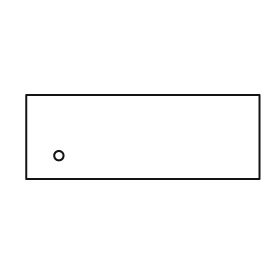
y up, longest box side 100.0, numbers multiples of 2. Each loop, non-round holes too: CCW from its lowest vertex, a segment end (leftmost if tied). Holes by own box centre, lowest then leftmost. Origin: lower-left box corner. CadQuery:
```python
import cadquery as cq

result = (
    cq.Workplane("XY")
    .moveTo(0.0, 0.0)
    .lineTo(100.0, 0.0)
    .lineTo(100.0, 36.0)
    .lineTo(0.0, 36.0)
    .close()
    .moveTo(14.0, 10.0)
    .circle(2.0)
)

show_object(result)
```